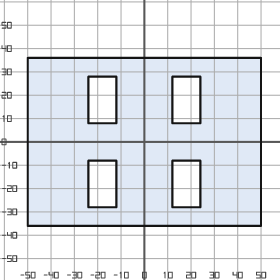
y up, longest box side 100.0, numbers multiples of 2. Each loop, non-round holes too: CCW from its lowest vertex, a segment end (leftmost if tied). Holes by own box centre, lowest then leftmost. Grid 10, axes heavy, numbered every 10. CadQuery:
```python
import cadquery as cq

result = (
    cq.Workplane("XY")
    .moveTo(-50.0, -36.0)
    .lineTo(50.0, -36.0)
    .lineTo(50.0, 36.0)
    .lineTo(-50.0, 36.0)
    .close()
    .moveTo(-24.0, -28.0)
    .lineTo(-12.0, -28.0)
    .lineTo(-12.0, -8.0)
    .lineTo(-24.0, -8.0)
    .close()
    .moveTo(12.0, -28.0)
    .lineTo(24.0, -28.0)
    .lineTo(24.0, -8.0)
    .lineTo(12.0, -8.0)
    .close()
    .moveTo(-24.0, 8.0)
    .lineTo(-12.0, 8.0)
    .lineTo(-12.0, 28.0)
    .lineTo(-24.0, 28.0)
    .close()
    .moveTo(12.0, 8.0)
    .lineTo(24.0, 8.0)
    .lineTo(24.0, 28.0)
    .lineTo(12.0, 28.0)
    .close()
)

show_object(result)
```